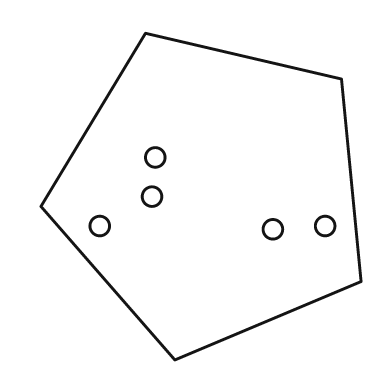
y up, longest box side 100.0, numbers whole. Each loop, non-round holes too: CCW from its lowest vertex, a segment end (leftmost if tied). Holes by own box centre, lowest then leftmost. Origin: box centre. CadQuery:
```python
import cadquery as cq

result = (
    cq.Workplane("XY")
    .moveTo(-8.0, -50.0)
    .lineTo(49.0, -26.0)
    .lineTo(43.0, 36.0)
    .lineTo(-17.0, 50.0)
    .lineTo(-49.0, -3.0)
    .close()
    .moveTo(22.0, -10.0)
    .circle(3.0)
    .moveTo(-31.0, -9.0)
    .circle(3.0)
    .moveTo(38.0, -9.0)
    .circle(3.0)
    .moveTo(-15.0, 0.0)
    .circle(3.0)
    .moveTo(-14.0, 12.0)
    .circle(3.0)
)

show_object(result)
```